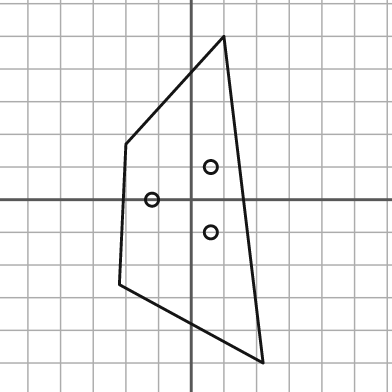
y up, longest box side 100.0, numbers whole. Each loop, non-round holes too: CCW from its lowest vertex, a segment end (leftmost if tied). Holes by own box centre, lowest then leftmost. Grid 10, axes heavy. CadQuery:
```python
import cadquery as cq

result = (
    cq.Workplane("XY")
    .moveTo(22.0, -50.0)
    .lineTo(10.0, 50.0)
    .lineTo(-20.0, 17.0)
    .lineTo(-22.0, -26.0)
    .close()
    .moveTo(6.0, -10.0)
    .circle(2.0)
    .moveTo(-12.0, 0.0)
    .circle(2.0)
    .moveTo(6.0, 10.0)
    .circle(2.0)
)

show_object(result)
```